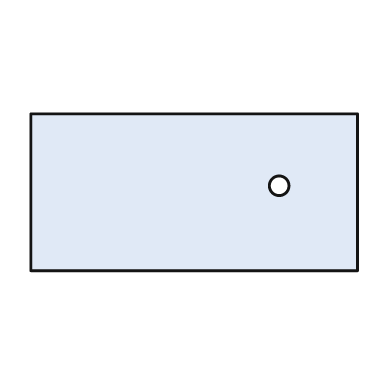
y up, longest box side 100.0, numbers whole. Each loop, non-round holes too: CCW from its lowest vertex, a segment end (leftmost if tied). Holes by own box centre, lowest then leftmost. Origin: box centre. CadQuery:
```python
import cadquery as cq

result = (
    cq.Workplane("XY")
    .moveTo(-50.0, -24.0)
    .lineTo(50.0, -24.0)
    .lineTo(50.0, 24.0)
    .lineTo(-50.0, 24.0)
    .close()
    .moveTo(26.0, 2.0)
    .circle(3.0)
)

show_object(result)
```